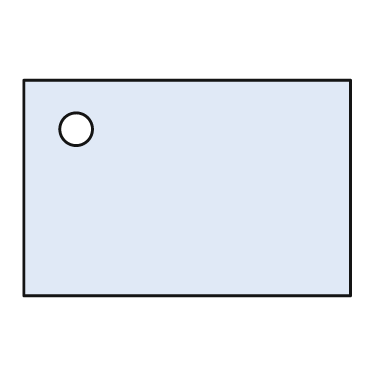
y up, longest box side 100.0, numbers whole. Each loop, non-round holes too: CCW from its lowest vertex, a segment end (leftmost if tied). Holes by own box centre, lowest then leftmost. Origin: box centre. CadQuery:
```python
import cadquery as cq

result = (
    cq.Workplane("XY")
    .moveTo(-50.0, -33.0)
    .lineTo(50.0, -33.0)
    .lineTo(50.0, 33.0)
    .lineTo(-50.0, 33.0)
    .close()
    .moveTo(-34.0, 18.0)
    .circle(5.0)
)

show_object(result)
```